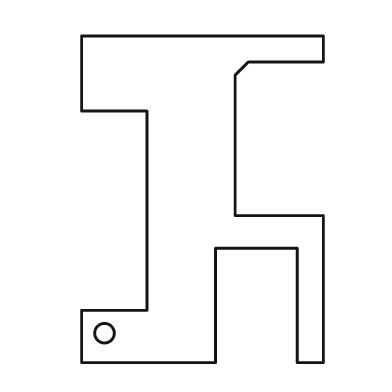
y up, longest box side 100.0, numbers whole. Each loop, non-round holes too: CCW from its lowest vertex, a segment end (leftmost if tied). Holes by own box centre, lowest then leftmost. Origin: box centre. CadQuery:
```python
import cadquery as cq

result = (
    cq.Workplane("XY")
    .moveTo(-37.0, -50.0)
    .lineTo(4.0, -50.0)
    .lineTo(4.0, -15.0)
    .lineTo(29.0, -15.0)
    .lineTo(29.0, -50.0)
    .lineTo(37.0, -50.0)
    .lineTo(37.0, -5.0)
    .lineTo(10.0, -5.0)
    .lineTo(10.0, 38.0)
    .lineTo(14.0, 42.0)
    .lineTo(37.0, 42.0)
    .lineTo(37.0, 50.0)
    .lineTo(-37.0, 50.0)
    .lineTo(-37.0, 27.0)
    .lineTo(-17.0, 27.0)
    .lineTo(-17.0, -34.0)
    .lineTo(-37.0, -34.0)
    .close()
    .moveTo(-30.0, -41.0)
    .circle(3.0)
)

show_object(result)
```